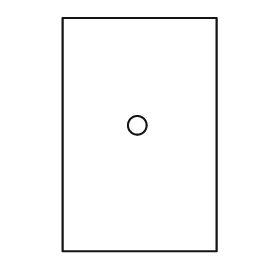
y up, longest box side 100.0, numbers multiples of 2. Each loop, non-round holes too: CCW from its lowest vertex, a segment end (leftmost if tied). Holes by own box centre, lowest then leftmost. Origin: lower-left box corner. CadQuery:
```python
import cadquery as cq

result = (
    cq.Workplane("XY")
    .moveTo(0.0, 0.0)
    .lineTo(66.0, 0.0)
    .lineTo(66.0, 100.0)
    .lineTo(0.0, 100.0)
    .close()
    .moveTo(32.0, 54.0)
    .circle(4.0)
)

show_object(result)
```